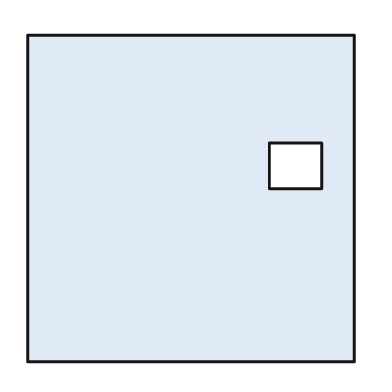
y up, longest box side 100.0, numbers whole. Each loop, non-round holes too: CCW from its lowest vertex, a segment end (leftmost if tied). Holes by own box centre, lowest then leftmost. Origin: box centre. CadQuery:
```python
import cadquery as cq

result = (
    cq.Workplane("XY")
    .moveTo(-50.0, -50.0)
    .lineTo(50.0, -50.0)
    .lineTo(50.0, 50.0)
    .lineTo(-50.0, 50.0)
    .close()
    .moveTo(24.0, 3.0)
    .lineTo(40.0, 3.0)
    .lineTo(40.0, 17.0)
    .lineTo(24.0, 17.0)
    .close()
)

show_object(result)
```